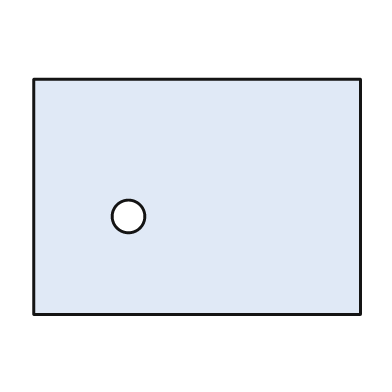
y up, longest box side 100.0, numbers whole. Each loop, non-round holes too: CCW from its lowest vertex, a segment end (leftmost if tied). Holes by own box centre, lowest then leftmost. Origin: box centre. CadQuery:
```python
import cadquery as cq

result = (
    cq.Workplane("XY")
    .moveTo(-50.0, -36.0)
    .lineTo(50.0, -36.0)
    .lineTo(50.0, 36.0)
    .lineTo(-50.0, 36.0)
    .close()
    .moveTo(-21.0, -6.0)
    .circle(5.0)
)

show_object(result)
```